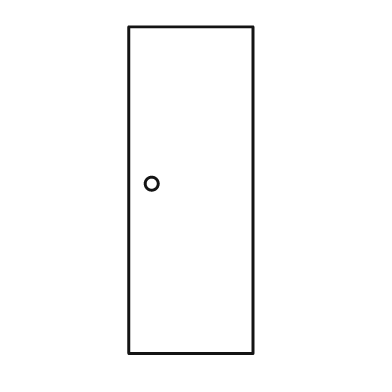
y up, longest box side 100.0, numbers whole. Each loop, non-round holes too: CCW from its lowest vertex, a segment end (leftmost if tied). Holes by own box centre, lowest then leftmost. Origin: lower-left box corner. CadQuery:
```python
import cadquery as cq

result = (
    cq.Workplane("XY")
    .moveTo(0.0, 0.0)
    .lineTo(38.0, 0.0)
    .lineTo(38.0, 100.0)
    .lineTo(0.0, 100.0)
    .close()
    .moveTo(7.0, 52.0)
    .circle(2.0)
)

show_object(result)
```